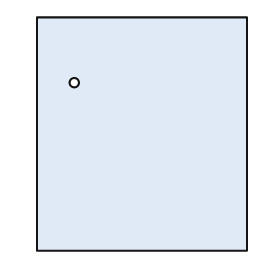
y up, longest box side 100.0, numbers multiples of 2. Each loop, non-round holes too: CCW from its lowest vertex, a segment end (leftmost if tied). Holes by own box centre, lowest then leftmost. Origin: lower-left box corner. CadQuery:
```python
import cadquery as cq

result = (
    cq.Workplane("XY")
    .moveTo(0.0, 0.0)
    .lineTo(90.0, 0.0)
    .lineTo(90.0, 100.0)
    .lineTo(0.0, 100.0)
    .close()
    .moveTo(16.0, 72.0)
    .circle(2.0)
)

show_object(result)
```